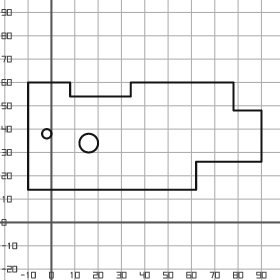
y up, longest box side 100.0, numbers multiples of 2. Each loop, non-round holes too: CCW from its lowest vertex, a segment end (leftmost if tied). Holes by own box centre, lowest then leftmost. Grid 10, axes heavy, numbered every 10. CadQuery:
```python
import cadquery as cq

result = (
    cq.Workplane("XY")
    .moveTo(-10.0, 14.0)
    .lineTo(62.0, 14.0)
    .lineTo(62.0, 26.0)
    .lineTo(90.0, 26.0)
    .lineTo(90.0, 48.0)
    .lineTo(78.0, 48.0)
    .lineTo(78.0, 60.0)
    .lineTo(34.0, 60.0)
    .lineTo(34.0, 54.0)
    .lineTo(8.0, 54.0)
    .lineTo(8.0, 60.0)
    .lineTo(-10.0, 60.0)
    .close()
    .moveTo(16.0, 34.0)
    .circle(4.0)
    .moveTo(-2.0, 38.0)
    .circle(2.0)
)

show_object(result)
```